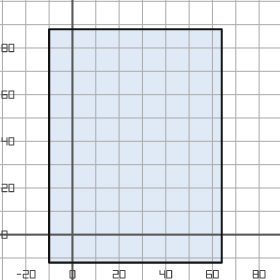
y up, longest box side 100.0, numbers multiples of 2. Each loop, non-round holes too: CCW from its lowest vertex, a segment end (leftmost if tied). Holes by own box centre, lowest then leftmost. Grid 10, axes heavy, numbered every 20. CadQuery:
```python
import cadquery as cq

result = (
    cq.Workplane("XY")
    .moveTo(-10.0, -12.0)
    .lineTo(64.0, -12.0)
    .lineTo(64.0, 88.0)
    .lineTo(-10.0, 88.0)
    .close()
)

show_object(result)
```